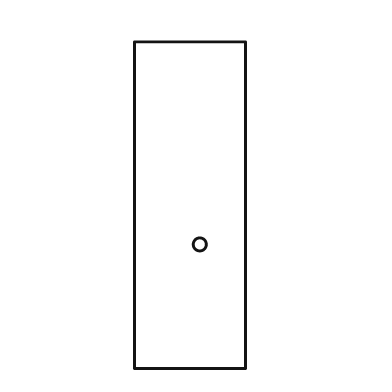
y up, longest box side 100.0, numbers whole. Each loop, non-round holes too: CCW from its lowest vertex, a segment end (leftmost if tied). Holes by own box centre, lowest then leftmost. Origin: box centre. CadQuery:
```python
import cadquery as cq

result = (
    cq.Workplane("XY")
    .moveTo(-17.0, -50.0)
    .lineTo(17.0, -50.0)
    .lineTo(17.0, 50.0)
    .lineTo(-17.0, 50.0)
    .close()
    .moveTo(3.0, -12.0)
    .circle(2.0)
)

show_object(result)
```